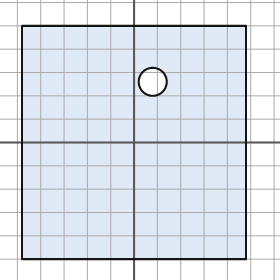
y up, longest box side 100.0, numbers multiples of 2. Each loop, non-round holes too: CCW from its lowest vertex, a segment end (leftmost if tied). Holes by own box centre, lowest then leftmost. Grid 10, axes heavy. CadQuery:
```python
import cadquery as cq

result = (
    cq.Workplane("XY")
    .moveTo(-48.0, -50.0)
    .lineTo(48.0, -50.0)
    .lineTo(48.0, 50.0)
    .lineTo(-48.0, 50.0)
    .close()
    .moveTo(8.0, 26.0)
    .circle(6.0)
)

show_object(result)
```